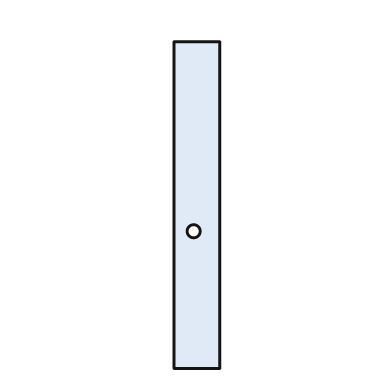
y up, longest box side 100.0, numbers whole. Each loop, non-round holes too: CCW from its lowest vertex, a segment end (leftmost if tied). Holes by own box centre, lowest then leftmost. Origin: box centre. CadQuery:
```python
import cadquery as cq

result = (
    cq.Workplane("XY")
    .moveTo(-7.0, -50.0)
    .lineTo(7.0, -50.0)
    .lineTo(7.0, 50.0)
    .lineTo(-7.0, 50.0)
    .close()
    .moveTo(-1.0, -8.0)
    .circle(2.0)
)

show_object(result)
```